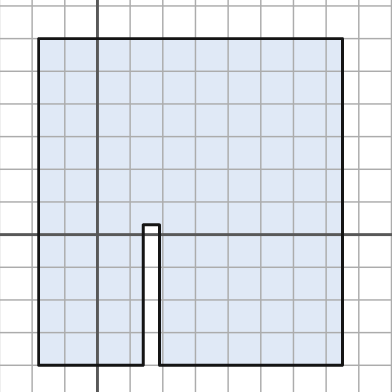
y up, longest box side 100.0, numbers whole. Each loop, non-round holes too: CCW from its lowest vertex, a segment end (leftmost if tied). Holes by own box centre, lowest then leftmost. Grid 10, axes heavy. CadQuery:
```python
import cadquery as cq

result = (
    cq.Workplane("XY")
    .moveTo(-18.0, -40.0)
    .lineTo(14.0, -40.0)
    .lineTo(14.0, 3.0)
    .lineTo(19.0, 3.0)
    .lineTo(19.0, -40.0)
    .lineTo(75.0, -40.0)
    .lineTo(75.0, 60.0)
    .lineTo(-18.0, 60.0)
    .close()
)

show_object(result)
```